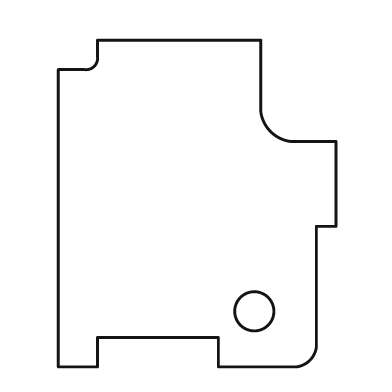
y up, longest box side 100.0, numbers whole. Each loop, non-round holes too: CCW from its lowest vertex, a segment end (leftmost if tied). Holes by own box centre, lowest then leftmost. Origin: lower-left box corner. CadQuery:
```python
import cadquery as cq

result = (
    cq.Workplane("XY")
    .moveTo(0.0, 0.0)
    .lineTo(12.0, 0.0)
    .lineTo(12.0, 9.0)
    .lineTo(49.0, 9.0)
    .lineTo(49.0, 0.0)
    .lineTo(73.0, 0.0)
    .threePointArc((77.0, 2.0), (79.0, 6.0))
    .lineTo(79.0, 43.0)
    .lineTo(85.0, 43.0)
    .lineTo(85.0, 69.0)
    .lineTo(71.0, 69.0)
    .threePointArc((65.0, 72.0), (62.0, 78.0))
    .lineTo(62.0, 100.0)
    .lineTo(12.0, 100.0)
    .lineTo(12.0, 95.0)
    .threePointArc((11.0, 92.0), (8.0, 91.0))
    .lineTo(0.0, 91.0)
    .close()
    .moveTo(60.0, 17.0)
    .circle(6.0)
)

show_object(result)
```